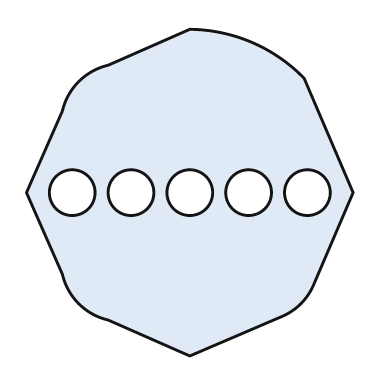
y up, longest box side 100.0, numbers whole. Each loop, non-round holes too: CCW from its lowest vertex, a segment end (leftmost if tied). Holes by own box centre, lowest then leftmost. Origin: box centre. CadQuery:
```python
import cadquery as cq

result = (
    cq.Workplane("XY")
    .moveTo(0.0, -50.0)
    .lineTo(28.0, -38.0)
    .threePointArc((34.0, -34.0), (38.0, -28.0))
    .lineTo(50.0, 0.0)
    .lineTo(35.0, 35.0)
    .threePointArc((19.0, 46.0), (0.0, 50.0))
    .lineTo(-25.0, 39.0)
    .threePointArc((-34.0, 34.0), (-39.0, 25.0))
    .lineTo(-50.0, 0.0)
    .lineTo(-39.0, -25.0)
    .threePointArc((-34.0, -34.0), (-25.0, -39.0))
    .close()
    .moveTo(-36.0, 0.0)
    .circle(7.0)
    .moveTo(-18.0, 0.0)
    .circle(7.0)
    .moveTo(0.0, 0.0)
    .circle(7.0)
    .moveTo(18.0, 0.0)
    .circle(7.0)
    .moveTo(36.0, 0.0)
    .circle(7.0)
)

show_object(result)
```